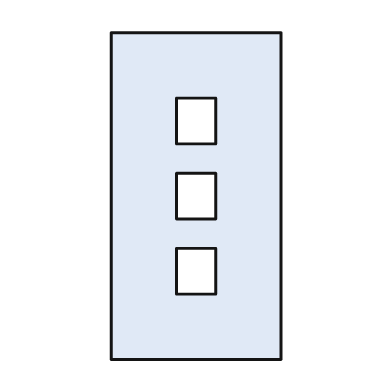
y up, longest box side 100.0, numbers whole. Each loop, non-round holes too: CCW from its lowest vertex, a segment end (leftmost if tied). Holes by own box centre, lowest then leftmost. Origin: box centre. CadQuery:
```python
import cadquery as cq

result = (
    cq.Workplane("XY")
    .moveTo(-26.0, -50.0)
    .lineTo(26.0, -50.0)
    .lineTo(26.0, 50.0)
    .lineTo(-26.0, 50.0)
    .close()
    .moveTo(-6.0, -30.0)
    .lineTo(6.0, -30.0)
    .lineTo(6.0, -16.0)
    .lineTo(-6.0, -16.0)
    .close()
    .moveTo(-6.0, -7.0)
    .lineTo(6.0, -7.0)
    .lineTo(6.0, 7.0)
    .lineTo(-6.0, 7.0)
    .close()
    .moveTo(-6.0, 16.0)
    .lineTo(6.0, 16.0)
    .lineTo(6.0, 30.0)
    .lineTo(-6.0, 30.0)
    .close()
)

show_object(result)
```